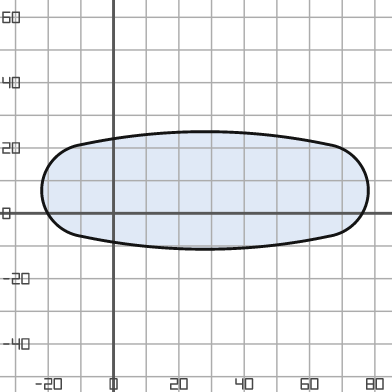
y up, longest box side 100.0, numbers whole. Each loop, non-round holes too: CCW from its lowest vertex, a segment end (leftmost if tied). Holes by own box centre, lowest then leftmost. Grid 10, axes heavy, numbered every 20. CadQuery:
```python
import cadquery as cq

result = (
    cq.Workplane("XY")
    .moveTo(-10.0, -7.0)
    .threePointArc((28.0, -11.0), (66.0, -7.0))
    .threePointArc((78.0, 7.0), (66.0, 21.0))
    .threePointArc((28.0, 25.0), (-10.0, 21.0))
    .threePointArc((-22.0, 7.0), (-10.0, -7.0))
    .close()
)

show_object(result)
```